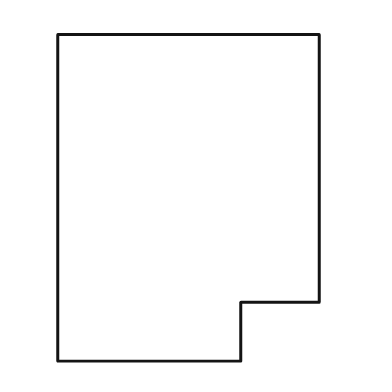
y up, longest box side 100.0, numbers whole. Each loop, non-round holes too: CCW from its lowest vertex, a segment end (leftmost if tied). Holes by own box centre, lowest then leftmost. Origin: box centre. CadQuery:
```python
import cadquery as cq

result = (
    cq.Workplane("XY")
    .moveTo(-40.0, -50.0)
    .lineTo(16.0, -50.0)
    .lineTo(16.0, -32.0)
    .lineTo(40.0, -32.0)
    .lineTo(40.0, 50.0)
    .lineTo(-40.0, 50.0)
    .close()
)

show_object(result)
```